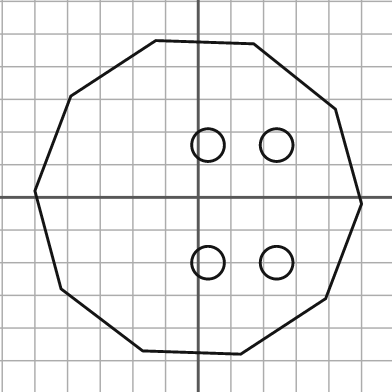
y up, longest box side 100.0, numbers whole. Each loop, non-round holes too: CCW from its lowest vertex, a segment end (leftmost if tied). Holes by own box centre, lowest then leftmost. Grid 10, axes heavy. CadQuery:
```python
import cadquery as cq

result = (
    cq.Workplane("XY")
    .moveTo(13.0, -48.0)
    .lineTo(39.0, -31.0)
    .lineTo(50.0, -2.0)
    .lineTo(42.0, 27.0)
    .lineTo(17.0, 47.0)
    .lineTo(-13.0, 48.0)
    .lineTo(-39.0, 31.0)
    .lineTo(-50.0, 2.0)
    .lineTo(-42.0, -28.0)
    .lineTo(-17.0, -47.0)
    .close()
    .moveTo(3.0, -20.0)
    .circle(5.0)
    .moveTo(24.0, -20.0)
    .circle(5.0)
    .moveTo(3.0, 16.0)
    .circle(5.0)
    .moveTo(24.0, 16.0)
    .circle(5.0)
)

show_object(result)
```